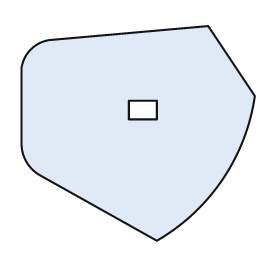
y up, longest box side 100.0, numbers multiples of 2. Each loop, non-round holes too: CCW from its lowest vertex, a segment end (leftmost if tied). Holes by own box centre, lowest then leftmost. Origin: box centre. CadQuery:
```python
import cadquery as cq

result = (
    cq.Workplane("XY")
    .moveTo(8.0, -46.0)
    .threePointArc((36.0, -20.0), (50.0, 16.0))
    .lineTo(30.0, 46.0)
    .lineTo(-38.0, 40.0)
    .threePointArc((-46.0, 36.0), (-50.0, 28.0))
    .lineTo(-50.0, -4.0)
    .threePointArc((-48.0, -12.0), (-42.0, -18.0))
    .close()
    .moveTo(-4.0, 6.0)
    .lineTo(8.0, 6.0)
    .lineTo(8.0, 14.0)
    .lineTo(-4.0, 14.0)
    .close()
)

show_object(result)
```